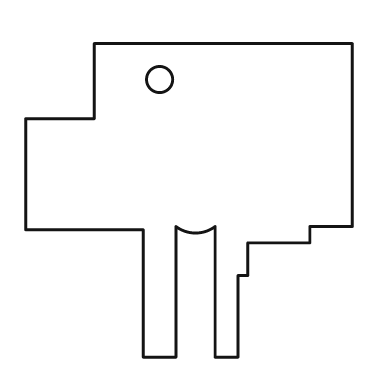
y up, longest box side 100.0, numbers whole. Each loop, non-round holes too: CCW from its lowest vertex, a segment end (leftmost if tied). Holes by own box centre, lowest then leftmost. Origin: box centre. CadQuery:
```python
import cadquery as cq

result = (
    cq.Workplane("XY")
    .moveTo(-14.0, -48.0)
    .lineTo(-4.0, -48.0)
    .lineTo(-4.0, -8.0)
    .threePointArc((2.0, -10.0), (8.0, -8.0))
    .lineTo(8.0, -48.0)
    .lineTo(15.0, -48.0)
    .lineTo(15.0, -23.0)
    .lineTo(18.0, -23.0)
    .lineTo(18.0, -13.0)
    .lineTo(37.0, -13.0)
    .lineTo(37.0, -8.0)
    .lineTo(50.0, -8.0)
    .lineTo(50.0, 48.0)
    .lineTo(-29.0, 48.0)
    .lineTo(-29.0, 25.0)
    .lineTo(-50.0, 25.0)
    .lineTo(-50.0, -9.0)
    .lineTo(-14.0, -9.0)
    .close()
    .moveTo(-9.0, 37.0)
    .circle(4.0)
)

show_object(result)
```